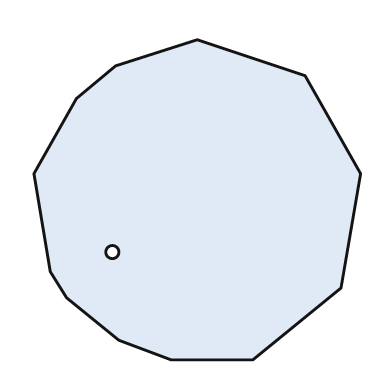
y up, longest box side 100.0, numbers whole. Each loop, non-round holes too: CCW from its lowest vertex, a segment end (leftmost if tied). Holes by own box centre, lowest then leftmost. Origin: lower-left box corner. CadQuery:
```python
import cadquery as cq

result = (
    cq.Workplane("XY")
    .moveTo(42.0, 0.0)
    .lineTo(67.0, 0.0)
    .lineTo(94.0, 22.0)
    .lineTo(100.0, 57.0)
    .lineTo(83.0, 87.0)
    .lineTo(50.0, 98.0)
    .lineTo(25.0, 90.0)
    .lineTo(13.0, 80.0)
    .lineTo(0.0, 57.0)
    .lineTo(5.0, 27.0)
    .lineTo(10.0, 19.0)
    .lineTo(26.0, 6.0)
    .close()
    .moveTo(24.0, 33.0)
    .circle(2.0)
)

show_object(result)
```